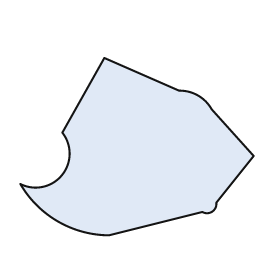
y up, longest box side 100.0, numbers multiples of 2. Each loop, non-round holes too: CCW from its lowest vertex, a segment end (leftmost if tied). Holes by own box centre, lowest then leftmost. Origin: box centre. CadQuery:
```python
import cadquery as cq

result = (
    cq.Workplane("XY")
    .moveTo(-12.0, -38.0)
    .lineTo(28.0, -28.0)
    .threePointArc((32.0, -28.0), (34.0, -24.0))
    .lineTo(50.0, -4.0)
    .lineTo(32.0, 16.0)
    .threePointArc((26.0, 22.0), (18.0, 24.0))
    .lineTo(-14.0, 38.0)
    .lineTo(-32.0, 6.0)
    .threePointArc((-32.0, -12.0), (-50.0, -16.0))
    .threePointArc((-34.0, -32.0), (-12.0, -38.0))
    .close()
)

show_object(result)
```